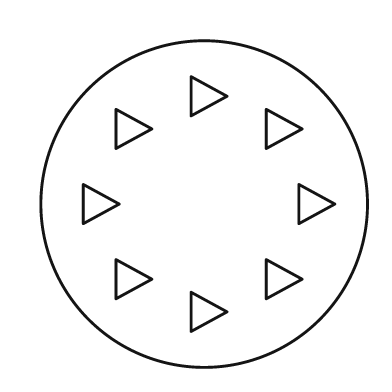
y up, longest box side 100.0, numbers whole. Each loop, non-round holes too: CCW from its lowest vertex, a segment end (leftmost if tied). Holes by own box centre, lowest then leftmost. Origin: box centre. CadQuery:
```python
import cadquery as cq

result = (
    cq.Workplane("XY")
    .moveTo(0.0, 0.0)
    .circle(50.0)
    .moveTo(-4.0, -39.0)
    .lineTo(7.0, -33.0)
    .lineTo(-4.0, -27.0)
    .close()
    .moveTo(-27.0, -29.0)
    .lineTo(-16.0, -23.0)
    .lineTo(-27.0, -17.0)
    .close()
    .moveTo(19.0, -29.0)
    .lineTo(30.0, -23.0)
    .lineTo(19.0, -17.0)
    .close()
    .moveTo(-37.0, -6.0)
    .lineTo(-26.0, 0.0)
    .lineTo(-37.0, 6.0)
    .close()
    .moveTo(29.0, -6.0)
    .lineTo(40.0, 0.0)
    .lineTo(29.0, 6.0)
    .close()
    .moveTo(-27.0, 17.0)
    .lineTo(-16.0, 23.0)
    .lineTo(-27.0, 29.0)
    .close()
    .moveTo(19.0, 17.0)
    .lineTo(30.0, 23.0)
    .lineTo(19.0, 29.0)
    .close()
    .moveTo(-4.0, 27.0)
    .lineTo(7.0, 33.0)
    .lineTo(-4.0, 39.0)
    .close()
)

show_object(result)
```